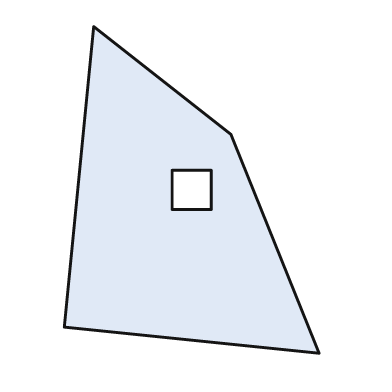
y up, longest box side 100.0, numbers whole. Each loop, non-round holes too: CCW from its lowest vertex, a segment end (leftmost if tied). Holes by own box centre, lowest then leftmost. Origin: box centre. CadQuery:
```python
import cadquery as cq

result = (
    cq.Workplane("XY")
    .moveTo(39.0, -50.0)
    .lineTo(12.0, 17.0)
    .lineTo(-30.0, 50.0)
    .lineTo(-39.0, -42.0)
    .close()
    .moveTo(-6.0, -6.0)
    .lineTo(6.0, -6.0)
    .lineTo(6.0, 6.0)
    .lineTo(-6.0, 6.0)
    .close()
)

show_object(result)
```